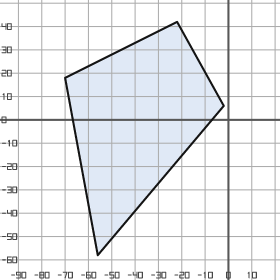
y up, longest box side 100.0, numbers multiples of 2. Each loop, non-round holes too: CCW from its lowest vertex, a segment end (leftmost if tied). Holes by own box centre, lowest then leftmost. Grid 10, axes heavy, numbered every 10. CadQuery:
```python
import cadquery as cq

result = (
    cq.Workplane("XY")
    .moveTo(-56.0, -58.0)
    .lineTo(-2.0, 6.0)
    .lineTo(-22.0, 42.0)
    .lineTo(-70.0, 18.0)
    .close()
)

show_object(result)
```